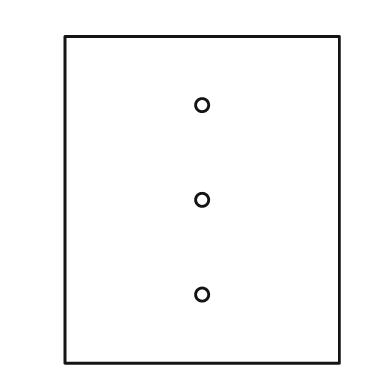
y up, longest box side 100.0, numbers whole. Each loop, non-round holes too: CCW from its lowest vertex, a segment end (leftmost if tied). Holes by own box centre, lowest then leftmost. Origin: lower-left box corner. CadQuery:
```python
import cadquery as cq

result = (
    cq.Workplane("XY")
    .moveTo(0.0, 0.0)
    .lineTo(84.0, 0.0)
    .lineTo(84.0, 100.0)
    .lineTo(0.0, 100.0)
    .close()
    .moveTo(42.0, 21.0)
    .circle(2.0)
    .moveTo(42.0, 50.0)
    .circle(2.0)
    .moveTo(42.0, 79.0)
    .circle(2.0)
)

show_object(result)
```